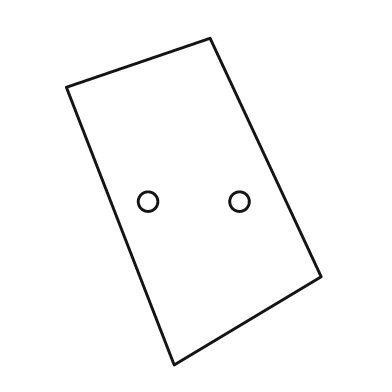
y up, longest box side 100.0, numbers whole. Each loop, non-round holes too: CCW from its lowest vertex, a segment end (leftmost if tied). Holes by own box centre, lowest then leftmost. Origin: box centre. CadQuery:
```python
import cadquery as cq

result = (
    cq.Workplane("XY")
    .moveTo(-6.0, -50.0)
    .lineTo(39.0, -23.0)
    .lineTo(5.0, 50.0)
    .lineTo(-39.0, 35.0)
    .close()
    .moveTo(-14.0, 0.0)
    .circle(3.0)
    .moveTo(14.0, 0.0)
    .circle(3.0)
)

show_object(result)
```